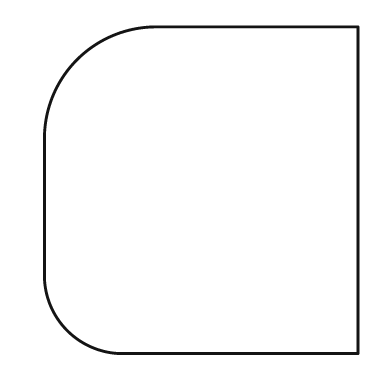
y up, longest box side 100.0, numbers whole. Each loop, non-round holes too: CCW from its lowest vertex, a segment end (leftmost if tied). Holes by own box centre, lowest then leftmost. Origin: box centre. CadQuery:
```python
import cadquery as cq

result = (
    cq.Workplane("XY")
    .moveTo(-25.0, -50.0)
    .lineTo(48.0, -50.0)
    .lineTo(48.0, 50.0)
    .lineTo(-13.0, 50.0)
    .threePointArc((-38.0, 40.0), (-48.0, 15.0))
    .lineTo(-48.0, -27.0)
    .threePointArc((-41.0, -43.0), (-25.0, -50.0))
    .close()
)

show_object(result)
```